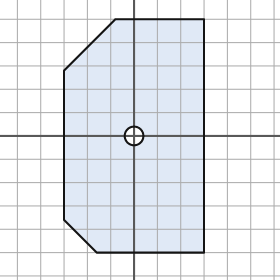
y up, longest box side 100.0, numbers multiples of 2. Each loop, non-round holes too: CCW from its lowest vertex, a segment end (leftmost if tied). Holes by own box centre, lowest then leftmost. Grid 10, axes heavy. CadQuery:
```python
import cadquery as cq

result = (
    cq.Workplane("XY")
    .moveTo(-16.0, -50.0)
    .lineTo(30.0, -50.0)
    .lineTo(30.0, 50.0)
    .lineTo(-8.0, 50.0)
    .lineTo(-30.0, 28.0)
    .lineTo(-30.0, -36.0)
    .close()
    .moveTo(0.0, 0.0)
    .circle(4.0)
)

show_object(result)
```